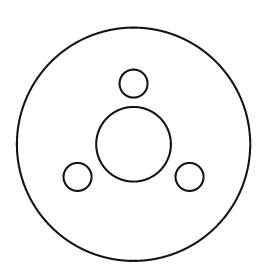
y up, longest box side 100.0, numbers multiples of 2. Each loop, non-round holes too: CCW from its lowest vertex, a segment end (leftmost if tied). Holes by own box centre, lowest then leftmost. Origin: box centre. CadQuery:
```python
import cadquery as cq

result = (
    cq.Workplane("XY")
    .moveTo(0.0, 0.0)
    .circle(50.0)
    .moveTo(-24.0, -14.0)
    .circle(6.0)
    .moveTo(24.0, -14.0)
    .circle(6.0)
    .moveTo(0.0, 0.0)
    .circle(16.0)
    .moveTo(0.0, 26.0)
    .circle(6.0)
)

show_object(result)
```